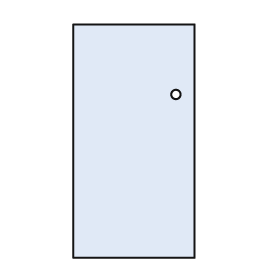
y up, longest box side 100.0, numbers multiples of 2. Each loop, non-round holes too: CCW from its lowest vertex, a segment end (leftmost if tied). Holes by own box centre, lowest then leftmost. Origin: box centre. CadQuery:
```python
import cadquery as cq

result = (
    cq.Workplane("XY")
    .moveTo(-26.0, -50.0)
    .lineTo(26.0, -50.0)
    .lineTo(26.0, 50.0)
    .lineTo(-26.0, 50.0)
    .close()
    .moveTo(18.0, 20.0)
    .circle(2.0)
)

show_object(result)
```